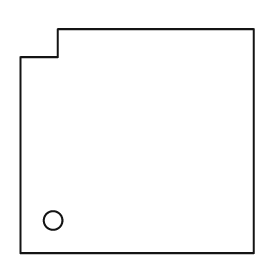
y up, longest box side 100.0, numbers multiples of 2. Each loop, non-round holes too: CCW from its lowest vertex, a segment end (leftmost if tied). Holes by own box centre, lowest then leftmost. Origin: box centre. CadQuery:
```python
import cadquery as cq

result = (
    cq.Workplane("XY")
    .moveTo(-50.0, -48.0)
    .lineTo(50.0, -48.0)
    .lineTo(50.0, 48.0)
    .lineTo(-34.0, 48.0)
    .lineTo(-34.0, 36.0)
    .lineTo(-50.0, 36.0)
    .close()
    .moveTo(-36.0, -34.0)
    .circle(4.0)
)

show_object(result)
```